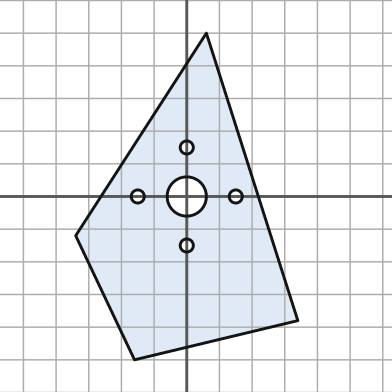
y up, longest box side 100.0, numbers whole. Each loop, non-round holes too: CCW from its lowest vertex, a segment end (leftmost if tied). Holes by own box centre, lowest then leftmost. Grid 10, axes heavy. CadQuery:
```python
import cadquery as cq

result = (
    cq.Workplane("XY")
    .moveTo(-16.0, -50.0)
    .lineTo(34.0, -38.0)
    .lineTo(6.0, 50.0)
    .lineTo(-34.0, -12.0)
    .close()
    .moveTo(0.0, -15.0)
    .circle(2.0)
    .moveTo(-15.0, 0.0)
    .circle(2.0)
    .moveTo(0.0, 0.0)
    .circle(6.0)
    .moveTo(15.0, 0.0)
    .circle(2.0)
    .moveTo(0.0, 15.0)
    .circle(2.0)
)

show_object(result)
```